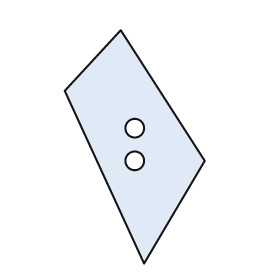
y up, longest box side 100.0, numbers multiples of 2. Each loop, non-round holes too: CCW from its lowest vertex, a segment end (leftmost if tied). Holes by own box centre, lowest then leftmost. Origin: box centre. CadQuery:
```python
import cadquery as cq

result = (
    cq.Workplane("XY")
    .moveTo(4.0, -50.0)
    .lineTo(30.0, -6.0)
    .lineTo(-6.0, 50.0)
    .lineTo(-30.0, 24.0)
    .close()
    .moveTo(0.0, -6.0)
    .circle(4.0)
    .moveTo(0.0, 8.0)
    .circle(4.0)
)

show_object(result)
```